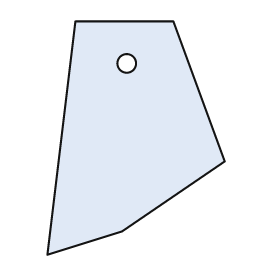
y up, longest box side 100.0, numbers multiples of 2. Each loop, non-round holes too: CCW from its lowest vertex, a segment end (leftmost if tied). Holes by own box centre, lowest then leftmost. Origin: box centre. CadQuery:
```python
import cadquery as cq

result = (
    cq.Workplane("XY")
    .moveTo(-38.0, -50.0)
    .lineTo(-6.0, -40.0)
    .lineTo(38.0, -10.0)
    .lineTo(16.0, 50.0)
    .lineTo(-26.0, 50.0)
    .close()
    .moveTo(-4.0, 32.0)
    .circle(4.0)
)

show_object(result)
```